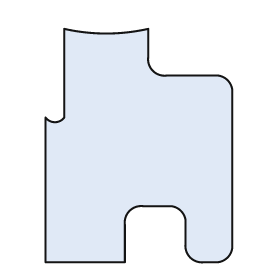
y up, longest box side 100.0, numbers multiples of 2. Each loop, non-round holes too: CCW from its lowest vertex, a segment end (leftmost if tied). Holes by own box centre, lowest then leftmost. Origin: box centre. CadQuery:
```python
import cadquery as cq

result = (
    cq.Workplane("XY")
    .moveTo(-40.0, -50.0)
    .lineTo(-6.0, -50.0)
    .lineTo(-6.0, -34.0)
    .threePointArc((-4.0, -28.0), (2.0, -26.0))
    .lineTo(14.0, -26.0)
    .threePointArc((18.0, -28.0), (20.0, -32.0))
    .lineTo(20.0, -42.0)
    .threePointArc((22.0, -48.0), (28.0, -50.0))
    .lineTo(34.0, -50.0)
    .threePointArc((38.0, -48.0), (40.0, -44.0))
    .lineTo(40.0, 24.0)
    .threePointArc((38.0, 28.0), (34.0, 30.0))
    .lineTo(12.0, 30.0)
    .threePointArc((6.0, 32.0), (4.0, 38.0))
    .lineTo(4.0, 50.0)
    .threePointArc((-14.0, 48.0), (-32.0, 50.0))
    .lineTo(-32.0, 12.0)
    .threePointArc((-36.0, 10.0), (-40.0, 12.0))
    .close()
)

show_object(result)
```